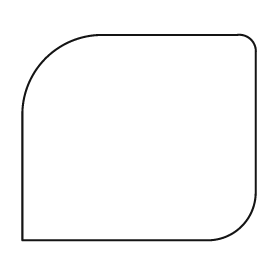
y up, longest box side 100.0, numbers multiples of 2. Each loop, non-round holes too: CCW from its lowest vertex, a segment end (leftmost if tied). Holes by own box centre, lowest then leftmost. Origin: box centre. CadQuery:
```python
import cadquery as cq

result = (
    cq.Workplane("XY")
    .moveTo(-50.0, -44.0)
    .lineTo(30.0, -44.0)
    .threePointArc((44.0, -38.0), (50.0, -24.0))
    .lineTo(50.0, 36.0)
    .threePointArc((48.0, 42.0), (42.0, 44.0))
    .lineTo(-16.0, 44.0)
    .threePointArc((-40.0, 34.0), (-50.0, 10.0))
    .close()
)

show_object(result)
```